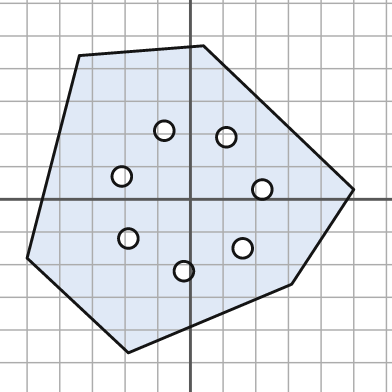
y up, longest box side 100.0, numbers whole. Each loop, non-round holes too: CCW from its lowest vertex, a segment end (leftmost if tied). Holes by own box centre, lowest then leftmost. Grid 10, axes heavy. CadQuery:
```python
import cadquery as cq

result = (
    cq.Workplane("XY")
    .moveTo(-19.0, -47.0)
    .lineTo(31.0, -26.0)
    .lineTo(50.0, 3.0)
    .lineTo(4.0, 47.0)
    .lineTo(-34.0, 44.0)
    .lineTo(-50.0, -18.0)
    .close()
    .moveTo(-2.0, -22.0)
    .circle(3.0)
    .moveTo(16.0, -15.0)
    .circle(3.0)
    .moveTo(-19.0, -12.0)
    .circle(3.0)
    .moveTo(22.0, 3.0)
    .circle(3.0)
    .moveTo(-21.0, 7.0)
    .circle(3.0)
    .moveTo(11.0, 19.0)
    .circle(3.0)
    .moveTo(-8.0, 21.0)
    .circle(3.0)
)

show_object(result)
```